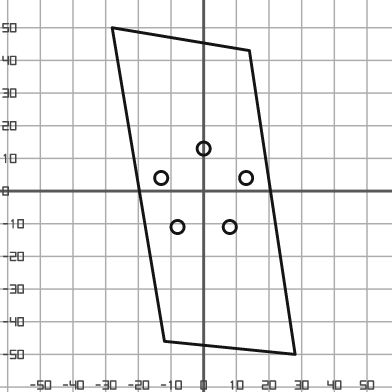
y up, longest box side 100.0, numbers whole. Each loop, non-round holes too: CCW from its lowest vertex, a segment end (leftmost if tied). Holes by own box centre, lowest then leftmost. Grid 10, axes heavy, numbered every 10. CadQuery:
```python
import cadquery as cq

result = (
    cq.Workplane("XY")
    .moveTo(28.0, -50.0)
    .lineTo(14.0, 43.0)
    .lineTo(-28.0, 50.0)
    .lineTo(-12.0, -46.0)
    .close()
    .moveTo(-8.0, -11.0)
    .circle(2.0)
    .moveTo(8.0, -11.0)
    .circle(2.0)
    .moveTo(-13.0, 4.0)
    .circle(2.0)
    .moveTo(13.0, 4.0)
    .circle(2.0)
    .moveTo(0.0, 13.0)
    .circle(2.0)
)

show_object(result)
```